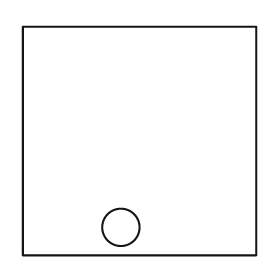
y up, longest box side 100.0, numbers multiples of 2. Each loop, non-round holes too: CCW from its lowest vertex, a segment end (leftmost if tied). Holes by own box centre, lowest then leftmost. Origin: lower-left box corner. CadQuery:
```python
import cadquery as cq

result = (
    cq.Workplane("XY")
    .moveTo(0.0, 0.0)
    .lineTo(100.0, 0.0)
    .lineTo(100.0, 98.0)
    .lineTo(0.0, 98.0)
    .close()
    .moveTo(42.0, 12.0)
    .circle(8.0)
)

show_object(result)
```